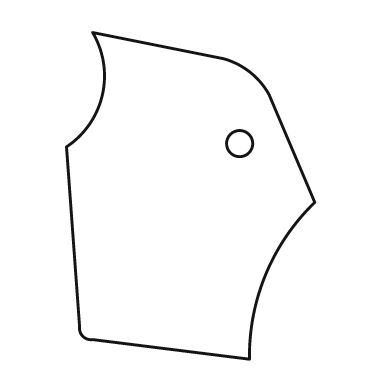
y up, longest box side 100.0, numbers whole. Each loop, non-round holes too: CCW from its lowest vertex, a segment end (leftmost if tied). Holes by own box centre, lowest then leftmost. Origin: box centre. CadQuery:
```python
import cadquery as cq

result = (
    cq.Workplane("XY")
    .moveTo(18.0, -50.0)
    .threePointArc((23.0, -24.0), (38.0, -2.0))
    .lineTo(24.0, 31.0)
    .threePointArc((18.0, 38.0), (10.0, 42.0))
    .lineTo(-30.0, 50.0)
    .threePointArc((-27.0, 31.0), (-38.0, 15.0))
    .lineTo(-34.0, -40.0)
    .threePointArc((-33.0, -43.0), (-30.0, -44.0))
    .close()
    .moveTo(15.0, 16.0)
    .circle(4.0)
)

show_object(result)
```